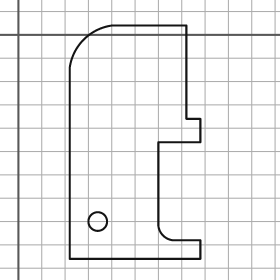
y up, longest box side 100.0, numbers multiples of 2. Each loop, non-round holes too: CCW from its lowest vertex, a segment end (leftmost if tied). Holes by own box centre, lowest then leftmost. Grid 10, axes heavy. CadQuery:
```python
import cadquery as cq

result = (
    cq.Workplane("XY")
    .moveTo(22.0, -96.0)
    .lineTo(78.0, -96.0)
    .lineTo(78.0, -88.0)
    .lineTo(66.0, -88.0)
    .threePointArc((62.0, -86.0), (60.0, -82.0))
    .lineTo(60.0, -46.0)
    .lineTo(78.0, -46.0)
    .lineTo(78.0, -36.0)
    .lineTo(72.0, -36.0)
    .lineTo(72.0, 4.0)
    .lineTo(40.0, 4.0)
    .threePointArc((28.0, -2.0), (22.0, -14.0))
    .close()
    .moveTo(34.0, -80.0)
    .circle(4.0)
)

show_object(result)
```